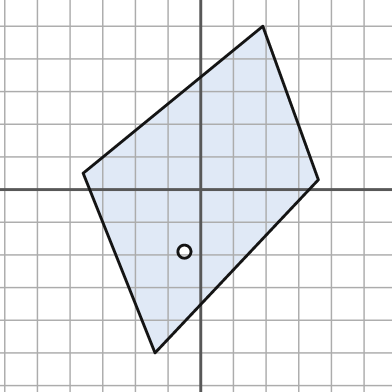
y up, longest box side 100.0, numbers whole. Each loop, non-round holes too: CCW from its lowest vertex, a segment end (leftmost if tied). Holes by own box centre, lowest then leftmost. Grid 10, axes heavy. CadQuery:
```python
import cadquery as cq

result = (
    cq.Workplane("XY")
    .moveTo(-14.0, -50.0)
    .lineTo(36.0, 3.0)
    .lineTo(19.0, 50.0)
    .lineTo(-36.0, 5.0)
    .close()
    .moveTo(-5.0, -19.0)
    .circle(2.0)
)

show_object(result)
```